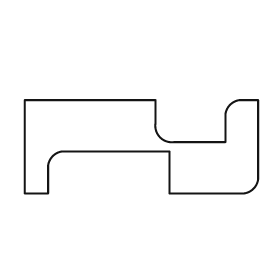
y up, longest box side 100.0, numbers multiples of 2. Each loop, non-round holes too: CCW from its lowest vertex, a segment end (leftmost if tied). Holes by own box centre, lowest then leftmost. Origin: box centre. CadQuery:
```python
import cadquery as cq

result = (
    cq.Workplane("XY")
    .moveTo(-50.0, -20.0)
    .lineTo(-40.0, -20.0)
    .lineTo(-40.0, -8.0)
    .threePointArc((-38.0, -4.0), (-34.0, -2.0))
    .lineTo(12.0, -2.0)
    .lineTo(12.0, -20.0)
    .lineTo(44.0, -20.0)
    .threePointArc((48.0, -18.0), (50.0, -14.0))
    .lineTo(50.0, 20.0)
    .lineTo(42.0, 20.0)
    .threePointArc((38.0, 18.0), (36.0, 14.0))
    .lineTo(36.0, 2.0)
    .lineTo(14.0, 2.0)
    .threePointArc((8.0, 4.0), (6.0, 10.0))
    .lineTo(6.0, 20.0)
    .lineTo(-50.0, 20.0)
    .close()
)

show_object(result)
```